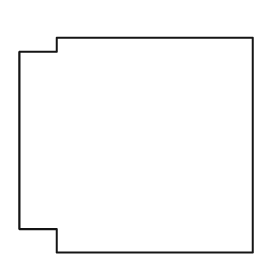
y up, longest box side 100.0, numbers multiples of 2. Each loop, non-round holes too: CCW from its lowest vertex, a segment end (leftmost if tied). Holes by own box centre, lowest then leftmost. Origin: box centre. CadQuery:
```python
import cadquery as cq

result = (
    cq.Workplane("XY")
    .moveTo(-34.0, -46.0)
    .lineTo(50.0, -46.0)
    .lineTo(50.0, 46.0)
    .lineTo(-34.0, 46.0)
    .lineTo(-34.0, 40.0)
    .lineTo(-50.0, 40.0)
    .lineTo(-50.0, -36.0)
    .lineTo(-34.0, -36.0)
    .close()
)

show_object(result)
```